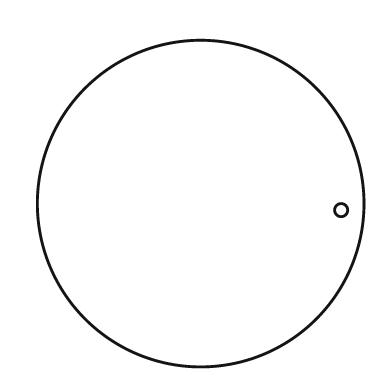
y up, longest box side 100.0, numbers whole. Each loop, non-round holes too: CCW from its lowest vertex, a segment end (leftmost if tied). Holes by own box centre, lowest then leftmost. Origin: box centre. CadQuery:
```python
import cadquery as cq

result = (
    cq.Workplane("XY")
    .moveTo(0.0, 0.0)
    .circle(50.0)
    .moveTo(43.0, -2.0)
    .circle(2.0)
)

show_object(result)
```